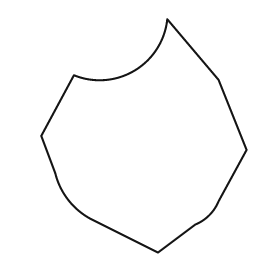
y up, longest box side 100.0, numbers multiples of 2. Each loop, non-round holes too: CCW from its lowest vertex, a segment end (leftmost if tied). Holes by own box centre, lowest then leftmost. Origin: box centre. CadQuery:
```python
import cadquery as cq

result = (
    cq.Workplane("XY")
    .moveTo(6.0, -50.0)
    .lineTo(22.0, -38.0)
    .threePointArc((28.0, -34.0), (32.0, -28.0))
    .lineTo(44.0, -6.0)
    .lineTo(32.0, 24.0)
    .lineTo(10.0, 50.0)
    .threePointArc((-4.0, 28.0), (-30.0, 26.0))
    .lineTo(-44.0, 0.0)
    .lineTo(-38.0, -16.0)
    .threePointArc((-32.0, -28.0), (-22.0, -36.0))
    .close()
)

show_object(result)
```